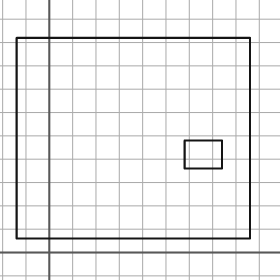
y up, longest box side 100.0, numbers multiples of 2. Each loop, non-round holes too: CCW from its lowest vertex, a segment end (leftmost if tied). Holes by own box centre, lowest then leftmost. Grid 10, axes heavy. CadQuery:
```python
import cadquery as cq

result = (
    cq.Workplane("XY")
    .moveTo(-14.0, 6.0)
    .lineTo(86.0, 6.0)
    .lineTo(86.0, 92.0)
    .lineTo(-14.0, 92.0)
    .close()
    .moveTo(58.0, 36.0)
    .lineTo(74.0, 36.0)
    .lineTo(74.0, 48.0)
    .lineTo(58.0, 48.0)
    .close()
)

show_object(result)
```